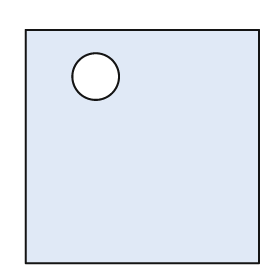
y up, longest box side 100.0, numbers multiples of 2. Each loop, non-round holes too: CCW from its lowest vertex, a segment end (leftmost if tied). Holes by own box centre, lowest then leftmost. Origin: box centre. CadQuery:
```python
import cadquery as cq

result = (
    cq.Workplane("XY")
    .moveTo(-50.0, -50.0)
    .lineTo(50.0, -50.0)
    .lineTo(50.0, 50.0)
    .lineTo(-50.0, 50.0)
    .close()
    .moveTo(-20.0, 30.0)
    .circle(10.0)
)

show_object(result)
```